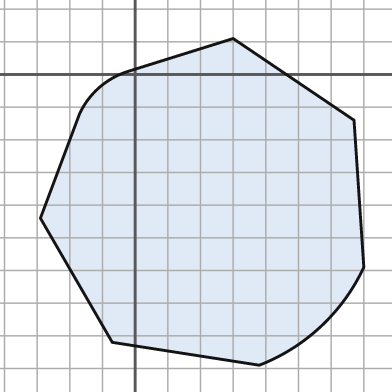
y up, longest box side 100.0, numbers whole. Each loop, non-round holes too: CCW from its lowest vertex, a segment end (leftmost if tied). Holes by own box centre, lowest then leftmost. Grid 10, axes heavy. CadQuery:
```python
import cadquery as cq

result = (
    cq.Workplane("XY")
    .moveTo(38.0, -89.0)
    .threePointArc((57.0, -77.0), (70.0, -59.0))
    .lineTo(67.0, -14.0)
    .lineTo(30.0, 11.0)
    .lineTo(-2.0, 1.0)
    .threePointArc((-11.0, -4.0), (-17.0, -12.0))
    .lineTo(-29.0, -44.0)
    .lineTo(-7.0, -82.0)
    .close()
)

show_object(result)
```